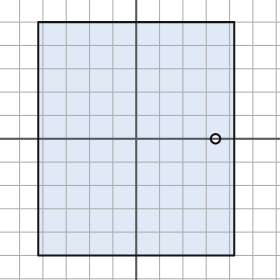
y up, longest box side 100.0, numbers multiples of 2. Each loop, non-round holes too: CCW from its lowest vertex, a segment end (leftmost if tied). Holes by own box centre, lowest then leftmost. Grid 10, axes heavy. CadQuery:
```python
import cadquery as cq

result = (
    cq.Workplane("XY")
    .moveTo(-42.0, -50.0)
    .lineTo(42.0, -50.0)
    .lineTo(42.0, 50.0)
    .lineTo(-42.0, 50.0)
    .close()
    .moveTo(34.0, 0.0)
    .circle(2.0)
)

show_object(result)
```